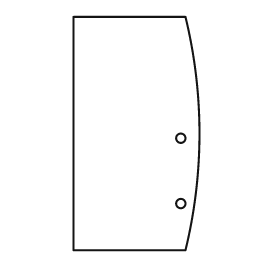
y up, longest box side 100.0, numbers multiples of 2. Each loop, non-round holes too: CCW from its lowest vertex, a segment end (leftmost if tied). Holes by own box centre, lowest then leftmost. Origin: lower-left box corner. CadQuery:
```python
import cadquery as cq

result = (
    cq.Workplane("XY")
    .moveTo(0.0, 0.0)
    .lineTo(48.0, 0.0)
    .threePointArc((54.0, 50.0), (48.0, 100.0))
    .lineTo(0.0, 100.0)
    .close()
    .moveTo(46.0, 20.0)
    .circle(2.0)
    .moveTo(46.0, 48.0)
    .circle(2.0)
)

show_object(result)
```